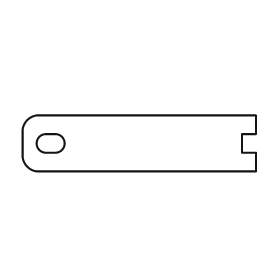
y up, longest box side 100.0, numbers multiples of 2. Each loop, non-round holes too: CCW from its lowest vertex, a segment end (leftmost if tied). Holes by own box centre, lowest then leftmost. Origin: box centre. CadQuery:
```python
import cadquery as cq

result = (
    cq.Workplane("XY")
    .moveTo(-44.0, -12.0)
    .lineTo(50.0, -12.0)
    .lineTo(50.0, -4.0)
    .lineTo(44.0, -4.0)
    .lineTo(44.0, 4.0)
    .lineTo(50.0, 4.0)
    .lineTo(50.0, 12.0)
    .lineTo(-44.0, 12.0)
    .threePointArc((-48.0, 10.0), (-50.0, 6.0))
    .lineTo(-50.0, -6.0)
    .threePointArc((-48.0, -10.0), (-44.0, -12.0))
    .close()
    .moveTo(-40.0, -4.0)
    .lineTo(-36.0, -4.0)
    .threePointArc((-32.0, 0.0), (-36.0, 4.0))
    .lineTo(-40.0, 4.0)
    .threePointArc((-44.0, 0.0), (-40.0, -4.0))
    .close()
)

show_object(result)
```